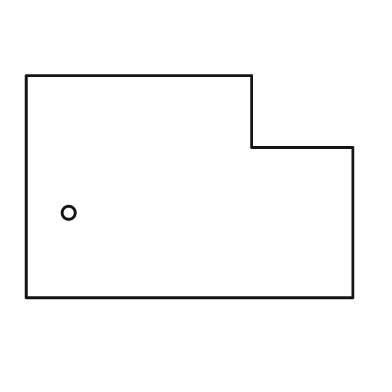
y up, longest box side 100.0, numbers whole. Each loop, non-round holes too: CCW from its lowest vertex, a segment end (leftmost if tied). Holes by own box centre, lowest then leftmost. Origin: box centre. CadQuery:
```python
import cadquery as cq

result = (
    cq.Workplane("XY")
    .moveTo(-50.0, -34.0)
    .lineTo(50.0, -34.0)
    .lineTo(50.0, 12.0)
    .lineTo(19.0, 12.0)
    .lineTo(19.0, 34.0)
    .lineTo(-50.0, 34.0)
    .close()
    .moveTo(-37.0, -8.0)
    .circle(2.0)
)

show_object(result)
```